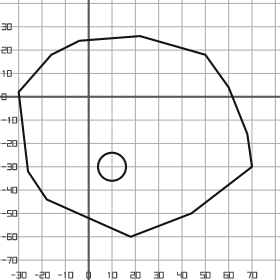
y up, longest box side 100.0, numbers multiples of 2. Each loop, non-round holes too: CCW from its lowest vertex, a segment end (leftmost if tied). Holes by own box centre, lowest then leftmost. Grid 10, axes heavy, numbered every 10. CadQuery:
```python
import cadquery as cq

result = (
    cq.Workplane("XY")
    .moveTo(18.0, -60.0)
    .lineTo(44.0, -50.0)
    .lineTo(70.0, -30.0)
    .lineTo(68.0, -16.0)
    .lineTo(60.0, 4.0)
    .lineTo(50.0, 18.0)
    .lineTo(22.0, 26.0)
    .lineTo(-4.0, 24.0)
    .lineTo(-16.0, 18.0)
    .lineTo(-30.0, 2.0)
    .lineTo(-26.0, -32.0)
    .lineTo(-18.0, -44.0)
    .close()
    .moveTo(10.0, -30.0)
    .circle(6.0)
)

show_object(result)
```